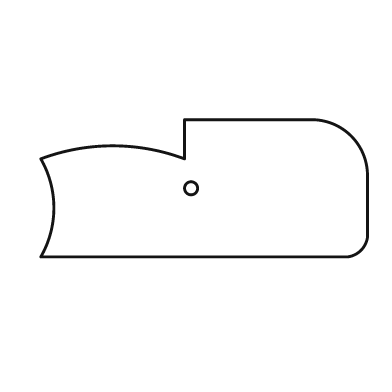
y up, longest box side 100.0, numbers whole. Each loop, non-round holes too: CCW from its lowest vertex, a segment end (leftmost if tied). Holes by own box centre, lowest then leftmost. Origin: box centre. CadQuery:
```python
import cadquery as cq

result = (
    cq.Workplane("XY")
    .moveTo(-50.0, -21.0)
    .lineTo(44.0, -21.0)
    .threePointArc((48.0, -19.0), (50.0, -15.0))
    .lineTo(50.0, 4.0)
    .threePointArc((45.0, 16.0), (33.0, 21.0))
    .lineTo(-6.0, 21.0)
    .lineTo(-6.0, 9.0)
    .threePointArc((-28.0, 13.0), (-50.0, 9.0))
    .threePointArc((-46.0, -6.0), (-50.0, -21.0))
    .close()
    .moveTo(-4.0, 0.0)
    .circle(2.0)
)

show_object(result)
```